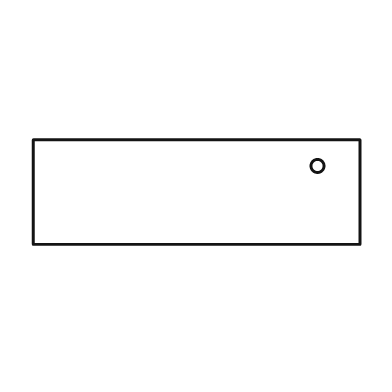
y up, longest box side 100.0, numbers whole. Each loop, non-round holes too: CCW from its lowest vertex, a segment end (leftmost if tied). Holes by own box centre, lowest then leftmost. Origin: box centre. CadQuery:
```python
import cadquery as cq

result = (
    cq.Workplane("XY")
    .moveTo(-50.0, -16.0)
    .lineTo(50.0, -16.0)
    .lineTo(50.0, 16.0)
    .lineTo(-50.0, 16.0)
    .close()
    .moveTo(37.0, 8.0)
    .circle(2.0)
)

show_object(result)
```